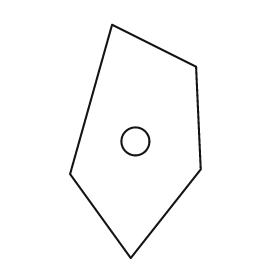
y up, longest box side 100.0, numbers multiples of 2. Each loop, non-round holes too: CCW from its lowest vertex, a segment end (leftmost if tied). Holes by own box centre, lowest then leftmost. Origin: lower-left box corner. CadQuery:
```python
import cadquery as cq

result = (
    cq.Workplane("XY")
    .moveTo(26.0, 0.0)
    .lineTo(56.0, 38.0)
    .lineTo(54.0, 82.0)
    .lineTo(18.0, 100.0)
    .lineTo(0.0, 36.0)
    .close()
    .moveTo(28.0, 50.0)
    .circle(6.0)
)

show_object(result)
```